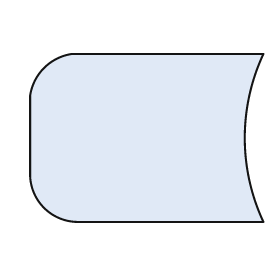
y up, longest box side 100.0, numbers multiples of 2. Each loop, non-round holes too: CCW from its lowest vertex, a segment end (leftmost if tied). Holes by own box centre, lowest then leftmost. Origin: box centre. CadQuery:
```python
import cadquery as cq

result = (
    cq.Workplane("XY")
    .moveTo(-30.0, -36.0)
    .lineTo(50.0, -36.0)
    .threePointArc((42.0, 0.0), (50.0, 36.0))
    .lineTo(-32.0, 36.0)
    .threePointArc((-44.0, 30.0), (-50.0, 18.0))
    .lineTo(-50.0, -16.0)
    .threePointArc((-44.0, -30.0), (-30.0, -36.0))
    .close()
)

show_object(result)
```